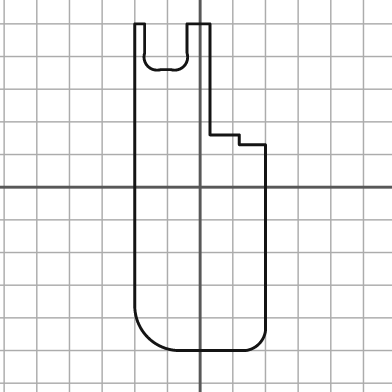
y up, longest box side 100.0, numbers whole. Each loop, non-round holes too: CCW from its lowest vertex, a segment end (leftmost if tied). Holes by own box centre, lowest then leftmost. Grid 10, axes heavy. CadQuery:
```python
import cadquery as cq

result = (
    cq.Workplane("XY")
    .moveTo(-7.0, -50.0)
    .lineTo(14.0, -50.0)
    .threePointArc((18.0, -48.0), (20.0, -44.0))
    .lineTo(20.0, 13.0)
    .lineTo(12.0, 13.0)
    .lineTo(12.0, 16.0)
    .lineTo(3.0, 16.0)
    .lineTo(3.0, 50.0)
    .lineTo(-4.0, 50.0)
    .lineTo(-4.0, 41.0)
    .threePointArc((-5.0, 37.0), (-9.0, 36.0))
    .lineTo(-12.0, 36.0)
    .threePointArc((-16.0, 37.0), (-17.0, 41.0))
    .lineTo(-17.0, 50.0)
    .lineTo(-20.0, 50.0)
    .lineTo(-20.0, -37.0)
    .threePointArc((-16.0, -46.0), (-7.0, -50.0))
    .close()
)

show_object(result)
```